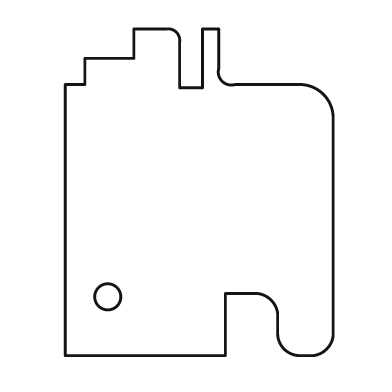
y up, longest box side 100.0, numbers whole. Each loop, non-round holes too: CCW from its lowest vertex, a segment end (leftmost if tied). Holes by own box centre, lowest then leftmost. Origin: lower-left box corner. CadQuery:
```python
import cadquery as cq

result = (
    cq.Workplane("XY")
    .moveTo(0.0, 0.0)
    .lineTo(49.0, 0.0)
    .lineTo(49.0, 19.0)
    .lineTo(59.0, 19.0)
    .threePointArc((63.0, 17.0), (65.0, 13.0))
    .lineTo(65.0, 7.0)
    .threePointArc((67.0, 2.0), (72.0, 0.0))
    .lineTo(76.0, 0.0)
    .threePointArc((80.0, 2.0), (82.0, 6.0))
    .lineTo(82.0, 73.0)
    .threePointArc((79.0, 80.0), (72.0, 83.0))
    .lineTo(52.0, 83.0)
    .threePointArc((48.0, 84.0), (47.0, 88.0))
    .lineTo(47.0, 100.0)
    .lineTo(42.0, 100.0)
    .lineTo(42.0, 82.0)
    .lineTo(35.0, 82.0)
    .lineTo(35.0, 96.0)
    .threePointArc((34.0, 99.0), (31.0, 100.0))
    .lineTo(21.0, 100.0)
    .lineTo(21.0, 91.0)
    .lineTo(6.0, 91.0)
    .lineTo(6.0, 83.0)
    .lineTo(0.0, 83.0)
    .close()
    .moveTo(13.0, 18.0)
    .circle(4.0)
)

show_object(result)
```